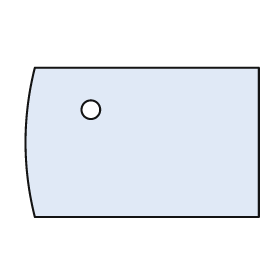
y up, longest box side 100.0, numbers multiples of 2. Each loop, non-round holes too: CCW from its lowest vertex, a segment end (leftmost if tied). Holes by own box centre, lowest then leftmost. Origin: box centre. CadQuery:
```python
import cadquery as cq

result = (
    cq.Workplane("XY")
    .moveTo(-46.0, -32.0)
    .lineTo(50.0, -32.0)
    .lineTo(50.0, 32.0)
    .lineTo(-46.0, 32.0)
    .threePointArc((-50.0, 0.0), (-46.0, -32.0))
    .close()
    .moveTo(-22.0, 14.0)
    .circle(4.0)
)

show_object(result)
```